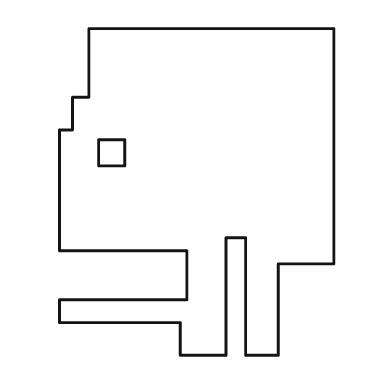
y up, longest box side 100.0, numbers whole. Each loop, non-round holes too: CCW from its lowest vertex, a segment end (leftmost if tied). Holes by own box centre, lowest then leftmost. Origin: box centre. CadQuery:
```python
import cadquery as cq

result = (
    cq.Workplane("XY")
    .moveTo(-5.0, -50.0)
    .lineTo(9.0, -50.0)
    .lineTo(9.0, -14.0)
    .lineTo(15.0, -14.0)
    .lineTo(15.0, -50.0)
    .lineTo(25.0, -50.0)
    .lineTo(25.0, -22.0)
    .lineTo(42.0, -22.0)
    .lineTo(42.0, 50.0)
    .lineTo(-33.0, 50.0)
    .lineTo(-33.0, 29.0)
    .lineTo(-38.0, 29.0)
    .lineTo(-38.0, 19.0)
    .lineTo(-42.0, 19.0)
    .lineTo(-42.0, -18.0)
    .lineTo(-3.0, -18.0)
    .lineTo(-3.0, -33.0)
    .lineTo(-42.0, -33.0)
    .lineTo(-42.0, -40.0)
    .lineTo(-5.0, -40.0)
    .close()
    .moveTo(-30.0, 8.0)
    .lineTo(-22.0, 8.0)
    .lineTo(-22.0, 16.0)
    .lineTo(-30.0, 16.0)
    .close()
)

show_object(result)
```